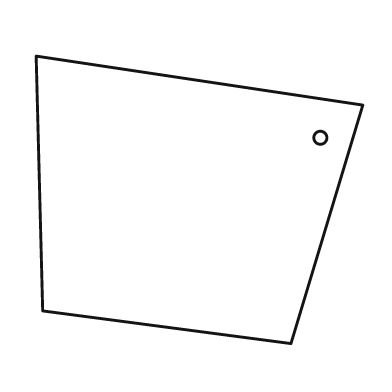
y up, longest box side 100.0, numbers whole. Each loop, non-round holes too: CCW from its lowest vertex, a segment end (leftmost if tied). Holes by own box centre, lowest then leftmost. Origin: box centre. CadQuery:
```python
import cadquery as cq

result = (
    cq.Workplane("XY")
    .moveTo(28.0, -44.0)
    .lineTo(50.0, 29.0)
    .lineTo(-50.0, 44.0)
    .lineTo(-48.0, -34.0)
    .close()
    .moveTo(37.0, 19.0)
    .circle(2.0)
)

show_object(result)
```